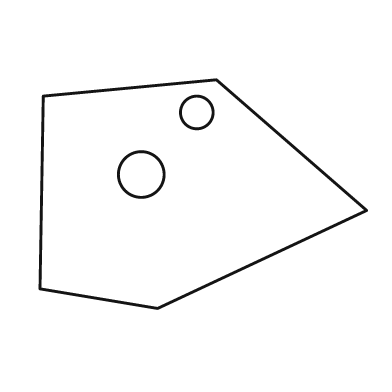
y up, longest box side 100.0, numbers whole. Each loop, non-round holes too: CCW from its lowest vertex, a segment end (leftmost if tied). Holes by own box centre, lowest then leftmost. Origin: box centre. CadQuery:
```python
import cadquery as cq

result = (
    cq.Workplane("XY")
    .moveTo(-14.0, -35.0)
    .lineTo(50.0, -5.0)
    .lineTo(4.0, 35.0)
    .lineTo(-49.0, 30.0)
    .lineTo(-50.0, -29.0)
    .close()
    .moveTo(-19.0, 6.0)
    .circle(7.0)
    .moveTo(-2.0, 25.0)
    .circle(5.0)
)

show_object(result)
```